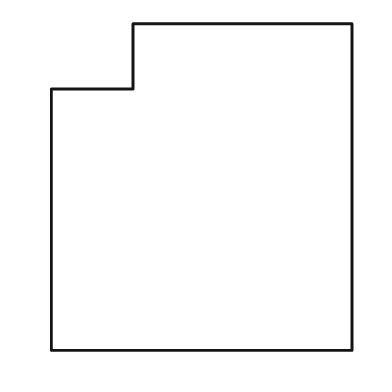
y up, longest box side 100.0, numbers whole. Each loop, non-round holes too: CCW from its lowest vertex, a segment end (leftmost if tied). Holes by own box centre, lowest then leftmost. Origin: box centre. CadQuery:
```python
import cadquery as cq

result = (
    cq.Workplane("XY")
    .moveTo(-46.0, -50.0)
    .lineTo(46.0, -50.0)
    .lineTo(46.0, 50.0)
    .lineTo(-21.0, 50.0)
    .lineTo(-21.0, 30.0)
    .lineTo(-46.0, 30.0)
    .close()
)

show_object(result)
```